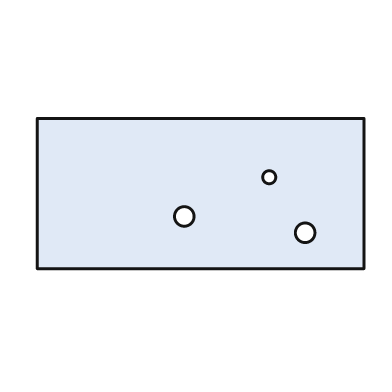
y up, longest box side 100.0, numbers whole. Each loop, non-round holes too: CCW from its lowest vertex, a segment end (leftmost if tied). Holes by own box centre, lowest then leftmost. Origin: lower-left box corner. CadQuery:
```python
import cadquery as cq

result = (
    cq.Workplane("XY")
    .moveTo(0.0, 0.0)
    .lineTo(100.0, 0.0)
    .lineTo(100.0, 46.0)
    .lineTo(0.0, 46.0)
    .close()
    .moveTo(82.0, 11.0)
    .circle(3.0)
    .moveTo(45.0, 16.0)
    .circle(3.0)
    .moveTo(71.0, 28.0)
    .circle(2.0)
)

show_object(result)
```